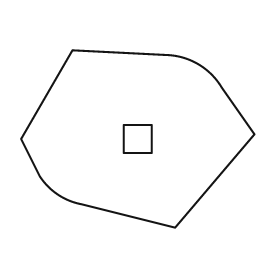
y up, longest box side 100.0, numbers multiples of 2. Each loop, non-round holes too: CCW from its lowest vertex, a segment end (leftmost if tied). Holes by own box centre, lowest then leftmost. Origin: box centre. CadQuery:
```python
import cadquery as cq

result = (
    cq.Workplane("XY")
    .moveTo(16.0, -38.0)
    .lineTo(50.0, 2.0)
    .lineTo(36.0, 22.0)
    .threePointArc((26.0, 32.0), (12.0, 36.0))
    .lineTo(-28.0, 38.0)
    .lineTo(-50.0, 0.0)
    .lineTo(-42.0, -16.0)
    .threePointArc((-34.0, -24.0), (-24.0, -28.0))
    .close()
    .moveTo(-6.0, -6.0)
    .lineTo(6.0, -6.0)
    .lineTo(6.0, 6.0)
    .lineTo(-6.0, 6.0)
    .close()
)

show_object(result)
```